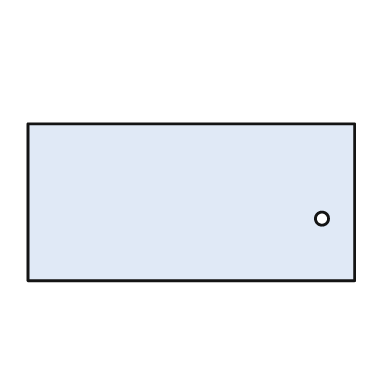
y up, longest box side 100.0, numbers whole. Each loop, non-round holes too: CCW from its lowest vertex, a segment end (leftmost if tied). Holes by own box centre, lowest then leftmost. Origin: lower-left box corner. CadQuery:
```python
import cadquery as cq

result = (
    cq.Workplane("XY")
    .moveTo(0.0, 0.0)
    .lineTo(100.0, 0.0)
    .lineTo(100.0, 48.0)
    .lineTo(0.0, 48.0)
    .close()
    .moveTo(90.0, 19.0)
    .circle(2.0)
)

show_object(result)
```